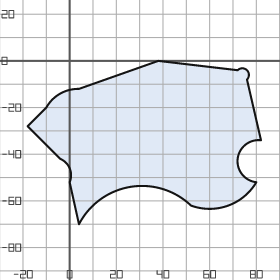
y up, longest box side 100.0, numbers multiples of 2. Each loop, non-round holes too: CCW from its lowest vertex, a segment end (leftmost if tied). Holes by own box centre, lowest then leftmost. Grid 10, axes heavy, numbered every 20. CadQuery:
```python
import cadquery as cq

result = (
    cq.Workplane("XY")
    .moveTo(4.0, -70.0)
    .threePointArc((26.0, -54.0), (52.0, -62.0))
    .threePointArc((68.0, -62.0), (80.0, -52.0))
    .threePointArc((72.0, -42.0), (82.0, -34.0))
    .lineTo(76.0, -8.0)
    .threePointArc((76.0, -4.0), (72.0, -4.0))
    .lineTo(38.0, 0.0)
    .lineTo(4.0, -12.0)
    .threePointArc((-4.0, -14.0), (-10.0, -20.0))
    .lineTo(-18.0, -28.0)
    .lineTo(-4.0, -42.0)
    .threePointArc((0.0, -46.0), (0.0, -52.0))
    .close()
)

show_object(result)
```